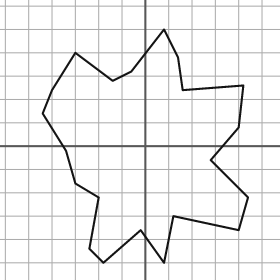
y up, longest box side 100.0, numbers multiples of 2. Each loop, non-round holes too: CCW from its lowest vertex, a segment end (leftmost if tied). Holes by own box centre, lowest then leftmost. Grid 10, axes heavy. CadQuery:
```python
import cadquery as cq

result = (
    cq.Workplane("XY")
    .moveTo(-18.0, -50.0)
    .lineTo(-2.0, -36.0)
    .lineTo(8.0, -50.0)
    .lineTo(12.0, -30.0)
    .lineTo(40.0, -36.0)
    .lineTo(44.0, -22.0)
    .lineTo(28.0, -6.0)
    .lineTo(40.0, 8.0)
    .lineTo(42.0, 26.0)
    .lineTo(16.0, 24.0)
    .lineTo(14.0, 38.0)
    .lineTo(8.0, 50.0)
    .lineTo(-6.0, 32.0)
    .lineTo(-14.0, 28.0)
    .lineTo(-30.0, 40.0)
    .lineTo(-40.0, 24.0)
    .lineTo(-44.0, 14.0)
    .lineTo(-34.0, -2.0)
    .lineTo(-30.0, -16.0)
    .lineTo(-20.0, -22.0)
    .lineTo(-24.0, -44.0)
    .close()
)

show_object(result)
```